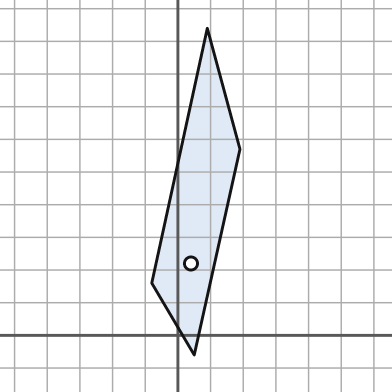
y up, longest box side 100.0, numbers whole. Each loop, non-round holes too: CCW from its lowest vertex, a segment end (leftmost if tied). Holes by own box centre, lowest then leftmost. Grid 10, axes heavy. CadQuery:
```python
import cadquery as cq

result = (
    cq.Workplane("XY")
    .moveTo(5.0, -6.0)
    .lineTo(19.0, 57.0)
    .lineTo(9.0, 94.0)
    .lineTo(-8.0, 16.0)
    .close()
    .moveTo(4.0, 22.0)
    .circle(2.0)
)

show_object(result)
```